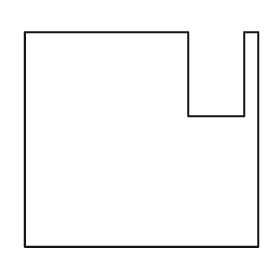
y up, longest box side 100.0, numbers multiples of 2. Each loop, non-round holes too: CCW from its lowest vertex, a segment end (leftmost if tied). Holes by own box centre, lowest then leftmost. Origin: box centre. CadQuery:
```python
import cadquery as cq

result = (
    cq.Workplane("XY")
    .moveTo(-50.0, -46.0)
    .lineTo(50.0, -46.0)
    .lineTo(50.0, 46.0)
    .lineTo(44.0, 46.0)
    .lineTo(44.0, 10.0)
    .lineTo(20.0, 10.0)
    .lineTo(20.0, 46.0)
    .lineTo(-50.0, 46.0)
    .close()
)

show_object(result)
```